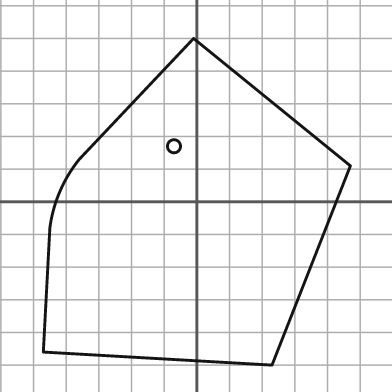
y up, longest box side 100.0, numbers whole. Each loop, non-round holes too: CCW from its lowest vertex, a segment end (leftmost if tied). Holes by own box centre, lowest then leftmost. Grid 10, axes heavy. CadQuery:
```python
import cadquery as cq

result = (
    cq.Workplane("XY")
    .moveTo(23.0, -50.0)
    .lineTo(47.0, 11.0)
    .lineTo(-1.0, 50.0)
    .lineTo(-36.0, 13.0)
    .threePointArc((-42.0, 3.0), (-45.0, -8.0))
    .lineTo(-47.0, -46.0)
    .close()
    .moveTo(-7.0, 17.0)
    .circle(2.0)
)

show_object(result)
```